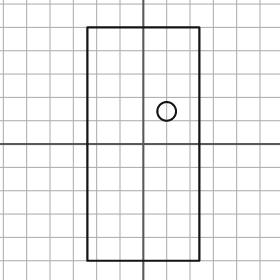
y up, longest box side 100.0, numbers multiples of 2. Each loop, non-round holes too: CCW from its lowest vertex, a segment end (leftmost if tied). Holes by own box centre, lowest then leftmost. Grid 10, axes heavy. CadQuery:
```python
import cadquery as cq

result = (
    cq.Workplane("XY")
    .moveTo(-24.0, -50.0)
    .lineTo(24.0, -50.0)
    .lineTo(24.0, 50.0)
    .lineTo(-24.0, 50.0)
    .close()
    .moveTo(10.0, 14.0)
    .circle(4.0)
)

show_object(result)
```